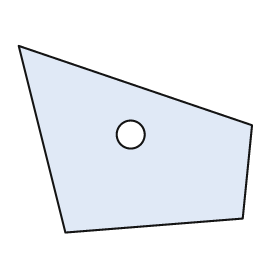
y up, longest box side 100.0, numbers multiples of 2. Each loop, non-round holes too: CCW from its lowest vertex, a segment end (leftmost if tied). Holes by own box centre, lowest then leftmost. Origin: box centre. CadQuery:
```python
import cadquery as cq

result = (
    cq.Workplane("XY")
    .moveTo(-30.0, -40.0)
    .lineTo(46.0, -34.0)
    .lineTo(50.0, 6.0)
    .lineTo(-50.0, 40.0)
    .close()
    .moveTo(-2.0, 2.0)
    .circle(6.0)
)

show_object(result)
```